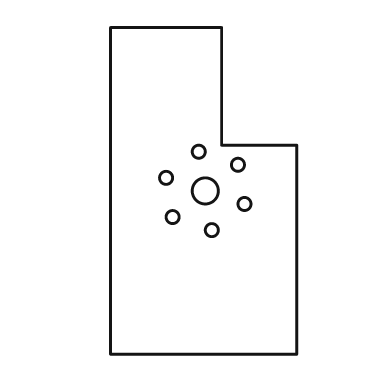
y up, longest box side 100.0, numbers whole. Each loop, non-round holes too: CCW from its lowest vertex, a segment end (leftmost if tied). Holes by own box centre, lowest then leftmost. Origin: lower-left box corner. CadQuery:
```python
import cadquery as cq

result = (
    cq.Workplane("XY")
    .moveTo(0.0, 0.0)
    .lineTo(57.0, 0.0)
    .lineTo(57.0, 64.0)
    .lineTo(34.0, 64.0)
    .lineTo(34.0, 100.0)
    .lineTo(0.0, 100.0)
    .close()
    .moveTo(31.0, 38.0)
    .circle(2.0)
    .moveTo(19.0, 42.0)
    .circle(2.0)
    .moveTo(41.0, 46.0)
    .circle(2.0)
    .moveTo(29.0, 50.0)
    .circle(4.0)
    .moveTo(17.0, 54.0)
    .circle(2.0)
    .moveTo(39.0, 58.0)
    .circle(2.0)
    .moveTo(27.0, 62.0)
    .circle(2.0)
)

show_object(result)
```